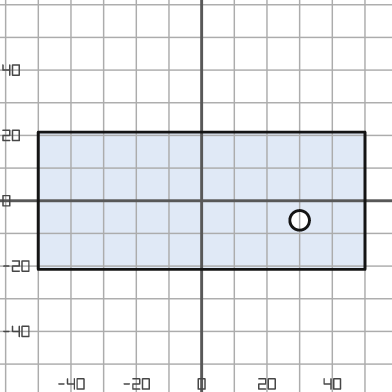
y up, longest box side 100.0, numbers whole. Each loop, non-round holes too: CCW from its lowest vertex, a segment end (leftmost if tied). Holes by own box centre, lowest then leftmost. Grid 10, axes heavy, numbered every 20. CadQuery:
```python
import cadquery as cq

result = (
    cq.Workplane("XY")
    .moveTo(-50.0, -21.0)
    .lineTo(50.0, -21.0)
    .lineTo(50.0, 21.0)
    .lineTo(-50.0, 21.0)
    .close()
    .moveTo(30.0, -6.0)
    .circle(3.0)
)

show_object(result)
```